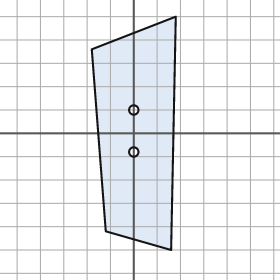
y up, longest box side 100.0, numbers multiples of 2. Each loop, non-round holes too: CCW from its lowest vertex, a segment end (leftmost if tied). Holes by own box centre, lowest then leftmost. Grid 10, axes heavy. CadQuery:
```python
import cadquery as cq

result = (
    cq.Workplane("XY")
    .moveTo(16.0, -50.0)
    .lineTo(18.0, 50.0)
    .lineTo(-18.0, 36.0)
    .lineTo(-12.0, -42.0)
    .close()
    .moveTo(0.0, -8.0)
    .circle(2.0)
    .moveTo(0.0, 10.0)
    .circle(2.0)
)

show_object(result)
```